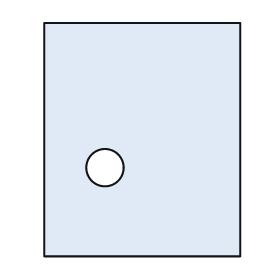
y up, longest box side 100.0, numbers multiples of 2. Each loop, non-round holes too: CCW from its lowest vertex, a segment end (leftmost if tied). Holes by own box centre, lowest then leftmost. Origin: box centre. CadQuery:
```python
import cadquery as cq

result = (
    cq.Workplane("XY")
    .moveTo(-42.0, -50.0)
    .lineTo(42.0, -50.0)
    .lineTo(42.0, 50.0)
    .lineTo(-42.0, 50.0)
    .close()
    .moveTo(-16.0, -12.0)
    .circle(8.0)
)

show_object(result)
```